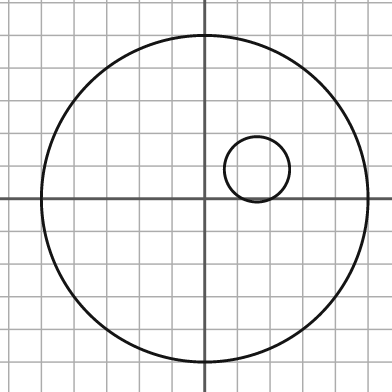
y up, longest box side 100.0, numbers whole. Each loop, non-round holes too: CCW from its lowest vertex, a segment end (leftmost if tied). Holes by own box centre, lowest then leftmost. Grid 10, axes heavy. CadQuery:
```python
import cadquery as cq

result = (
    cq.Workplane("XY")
    .moveTo(0.0, 0.0)
    .circle(50.0)
    .moveTo(16.0, 9.0)
    .circle(10.0)
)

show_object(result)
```